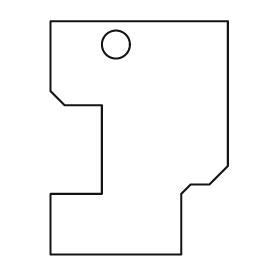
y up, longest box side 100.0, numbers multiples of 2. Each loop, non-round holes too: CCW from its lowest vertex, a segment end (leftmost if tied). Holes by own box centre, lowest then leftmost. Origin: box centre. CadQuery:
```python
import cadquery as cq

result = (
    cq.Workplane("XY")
    .moveTo(-38.0, -50.0)
    .lineTo(18.0, -50.0)
    .lineTo(18.0, -24.0)
    .lineTo(22.0, -20.0)
    .lineTo(30.0, -20.0)
    .lineTo(38.0, -12.0)
    .lineTo(38.0, 50.0)
    .lineTo(-38.0, 50.0)
    .lineTo(-38.0, 20.0)
    .lineTo(-32.0, 14.0)
    .lineTo(-16.0, 14.0)
    .lineTo(-16.0, -24.0)
    .lineTo(-38.0, -24.0)
    .close()
    .moveTo(-10.0, 40.0)
    .circle(6.0)
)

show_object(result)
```